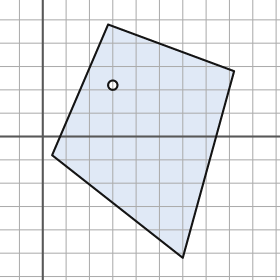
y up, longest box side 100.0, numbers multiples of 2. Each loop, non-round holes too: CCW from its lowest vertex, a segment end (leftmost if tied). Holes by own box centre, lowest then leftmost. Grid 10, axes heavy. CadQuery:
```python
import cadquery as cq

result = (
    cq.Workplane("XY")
    .moveTo(60.0, -52.0)
    .lineTo(82.0, 28.0)
    .lineTo(28.0, 48.0)
    .lineTo(4.0, -8.0)
    .close()
    .moveTo(30.0, 22.0)
    .circle(2.0)
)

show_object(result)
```